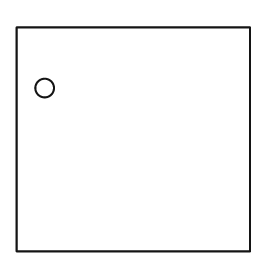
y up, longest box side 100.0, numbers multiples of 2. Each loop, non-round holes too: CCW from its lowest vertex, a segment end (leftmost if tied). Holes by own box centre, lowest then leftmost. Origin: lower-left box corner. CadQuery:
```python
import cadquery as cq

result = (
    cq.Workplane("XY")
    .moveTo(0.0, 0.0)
    .lineTo(100.0, 0.0)
    .lineTo(100.0, 96.0)
    .lineTo(0.0, 96.0)
    .close()
    .moveTo(12.0, 70.0)
    .circle(4.0)
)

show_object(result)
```